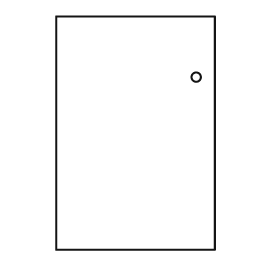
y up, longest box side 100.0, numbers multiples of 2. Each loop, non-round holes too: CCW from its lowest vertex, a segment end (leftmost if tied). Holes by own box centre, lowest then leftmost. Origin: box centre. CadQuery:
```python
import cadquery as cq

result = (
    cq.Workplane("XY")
    .moveTo(-34.0, -50.0)
    .lineTo(34.0, -50.0)
    .lineTo(34.0, 50.0)
    .lineTo(-34.0, 50.0)
    .close()
    .moveTo(26.0, 24.0)
    .circle(2.0)
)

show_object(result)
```